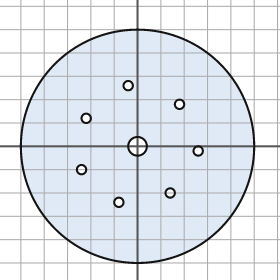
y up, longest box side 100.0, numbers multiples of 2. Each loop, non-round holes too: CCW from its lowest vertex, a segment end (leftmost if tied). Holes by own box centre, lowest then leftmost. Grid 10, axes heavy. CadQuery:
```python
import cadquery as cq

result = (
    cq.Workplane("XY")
    .moveTo(0.0, 0.0)
    .circle(50.0)
    .moveTo(-8.0, -24.0)
    .circle(2.0)
    .moveTo(14.0, -20.0)
    .circle(2.0)
    .moveTo(-24.0, -10.0)
    .circle(2.0)
    .moveTo(26.0, -2.0)
    .circle(2.0)
    .moveTo(0.0, 0.0)
    .circle(4.0)
    .moveTo(-22.0, 12.0)
    .circle(2.0)
    .moveTo(18.0, 18.0)
    .circle(2.0)
    .moveTo(-4.0, 26.0)
    .circle(2.0)
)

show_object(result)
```